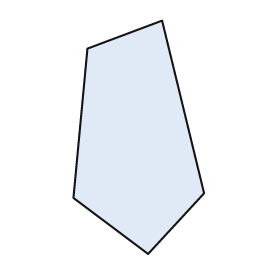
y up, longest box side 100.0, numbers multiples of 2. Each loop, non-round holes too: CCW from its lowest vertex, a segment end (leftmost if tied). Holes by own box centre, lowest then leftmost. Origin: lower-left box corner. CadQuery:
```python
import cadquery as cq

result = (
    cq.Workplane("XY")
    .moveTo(32.0, 0.0)
    .lineTo(56.0, 26.0)
    .lineTo(38.0, 100.0)
    .lineTo(6.0, 88.0)
    .lineTo(0.0, 24.0)
    .close()
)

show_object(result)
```